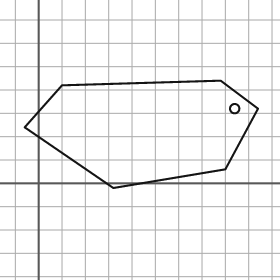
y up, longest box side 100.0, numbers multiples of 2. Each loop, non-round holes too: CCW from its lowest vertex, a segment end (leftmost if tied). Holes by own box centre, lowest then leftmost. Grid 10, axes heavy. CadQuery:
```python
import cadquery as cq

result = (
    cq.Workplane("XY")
    .moveTo(32.0, -2.0)
    .lineTo(80.0, 6.0)
    .lineTo(94.0, 32.0)
    .lineTo(78.0, 44.0)
    .lineTo(10.0, 42.0)
    .lineTo(-6.0, 24.0)
    .close()
    .moveTo(84.0, 32.0)
    .circle(2.0)
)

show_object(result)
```